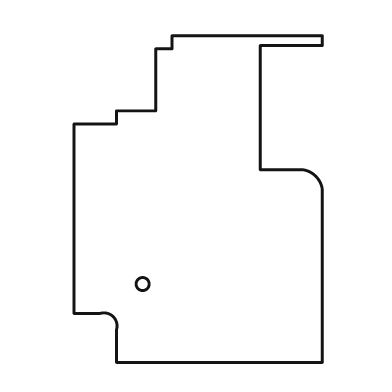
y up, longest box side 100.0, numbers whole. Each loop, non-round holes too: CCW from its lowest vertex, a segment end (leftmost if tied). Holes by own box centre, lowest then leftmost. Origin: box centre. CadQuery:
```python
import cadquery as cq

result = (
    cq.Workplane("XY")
    .moveTo(-25.0, -50.0)
    .lineTo(38.0, -50.0)
    .lineTo(38.0, 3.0)
    .threePointArc((36.0, 7.0), (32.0, 9.0))
    .lineTo(19.0, 9.0)
    .lineTo(19.0, 47.0)
    .lineTo(38.0, 47.0)
    .lineTo(38.0, 50.0)
    .lineTo(-8.0, 50.0)
    .lineTo(-8.0, 46.0)
    .lineTo(-13.0, 46.0)
    .lineTo(-13.0, 27.0)
    .lineTo(-25.0, 27.0)
    .lineTo(-25.0, 23.0)
    .lineTo(-38.0, 23.0)
    .lineTo(-38.0, -35.0)
    .lineTo(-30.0, -35.0)
    .threePointArc((-26.0, -36.0), (-25.0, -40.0))
    .close()
    .moveTo(-17.0, -26.0)
    .circle(2.0)
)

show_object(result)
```